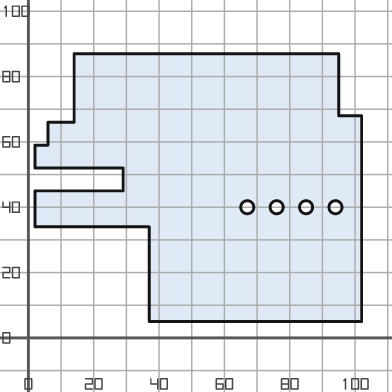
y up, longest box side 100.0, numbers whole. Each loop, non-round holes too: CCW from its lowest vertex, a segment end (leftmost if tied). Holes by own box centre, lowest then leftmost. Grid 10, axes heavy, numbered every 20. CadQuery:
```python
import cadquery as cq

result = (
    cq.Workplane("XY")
    .moveTo(37.0, 5.0)
    .lineTo(102.0, 5.0)
    .lineTo(102.0, 68.0)
    .lineTo(95.0, 68.0)
    .lineTo(95.0, 87.0)
    .lineTo(14.0, 87.0)
    .lineTo(14.0, 66.0)
    .lineTo(6.0, 66.0)
    .lineTo(6.0, 59.0)
    .lineTo(2.0, 59.0)
    .lineTo(2.0, 52.0)
    .lineTo(29.0, 52.0)
    .lineTo(29.0, 45.0)
    .lineTo(2.0, 45.0)
    .lineTo(2.0, 34.0)
    .lineTo(37.0, 34.0)
    .close()
    .moveTo(67.0, 40.0)
    .circle(2.0)
    .moveTo(76.0, 40.0)
    .circle(2.0)
    .moveTo(85.0, 40.0)
    .circle(2.0)
    .moveTo(94.0, 40.0)
    .circle(2.0)
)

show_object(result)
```